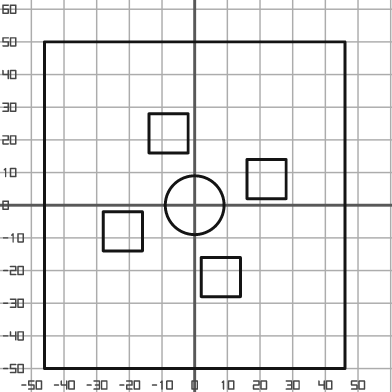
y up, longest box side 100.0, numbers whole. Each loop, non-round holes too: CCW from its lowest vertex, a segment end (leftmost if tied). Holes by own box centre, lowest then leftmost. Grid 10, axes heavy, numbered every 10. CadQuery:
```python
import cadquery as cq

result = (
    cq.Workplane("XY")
    .moveTo(-46.0, -50.0)
    .lineTo(46.0, -50.0)
    .lineTo(46.0, 50.0)
    .lineTo(-46.0, 50.0)
    .close()
    .moveTo(2.0, -28.0)
    .lineTo(14.0, -28.0)
    .lineTo(14.0, -16.0)
    .lineTo(2.0, -16.0)
    .close()
    .moveTo(-28.0, -14.0)
    .lineTo(-16.0, -14.0)
    .lineTo(-16.0, -2.0)
    .lineTo(-28.0, -2.0)
    .close()
    .moveTo(0.0, 0.0)
    .circle(9.0)
    .moveTo(16.0, 2.0)
    .lineTo(28.0, 2.0)
    .lineTo(28.0, 14.0)
    .lineTo(16.0, 14.0)
    .close()
    .moveTo(-14.0, 16.0)
    .lineTo(-2.0, 16.0)
    .lineTo(-2.0, 28.0)
    .lineTo(-14.0, 28.0)
    .close()
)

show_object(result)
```